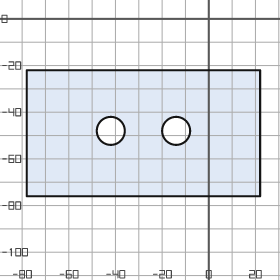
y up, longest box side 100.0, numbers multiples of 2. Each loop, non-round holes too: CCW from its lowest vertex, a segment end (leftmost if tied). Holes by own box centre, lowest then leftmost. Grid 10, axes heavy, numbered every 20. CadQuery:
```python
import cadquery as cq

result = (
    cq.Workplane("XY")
    .moveTo(-78.0, -76.0)
    .lineTo(22.0, -76.0)
    .lineTo(22.0, -22.0)
    .lineTo(-78.0, -22.0)
    .close()
    .moveTo(-42.0, -48.0)
    .circle(6.0)
    .moveTo(-14.0, -48.0)
    .circle(6.0)
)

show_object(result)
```